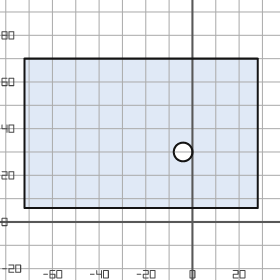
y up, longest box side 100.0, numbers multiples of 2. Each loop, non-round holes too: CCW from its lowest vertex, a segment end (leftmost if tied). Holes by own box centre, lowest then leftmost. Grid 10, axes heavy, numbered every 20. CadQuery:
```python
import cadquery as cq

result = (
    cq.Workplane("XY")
    .moveTo(-72.0, 6.0)
    .lineTo(28.0, 6.0)
    .lineTo(28.0, 70.0)
    .lineTo(-72.0, 70.0)
    .close()
    .moveTo(-4.0, 30.0)
    .circle(4.0)
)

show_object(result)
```